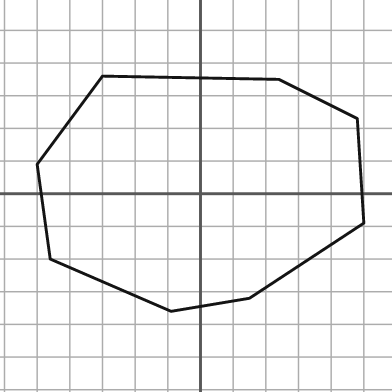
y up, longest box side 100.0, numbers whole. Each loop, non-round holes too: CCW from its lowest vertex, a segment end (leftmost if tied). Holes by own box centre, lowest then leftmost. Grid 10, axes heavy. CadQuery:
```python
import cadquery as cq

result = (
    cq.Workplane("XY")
    .moveTo(-9.0, -36.0)
    .lineTo(15.0, -32.0)
    .lineTo(50.0, -9.0)
    .lineTo(48.0, 23.0)
    .lineTo(24.0, 35.0)
    .lineTo(-30.0, 36.0)
    .lineTo(-50.0, 9.0)
    .lineTo(-46.0, -20.0)
    .close()
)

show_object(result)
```